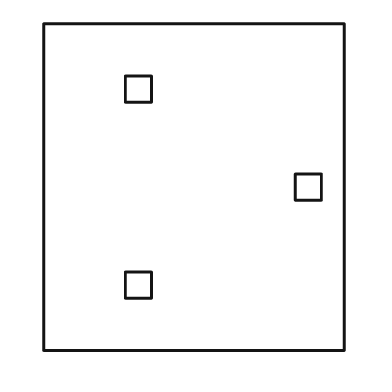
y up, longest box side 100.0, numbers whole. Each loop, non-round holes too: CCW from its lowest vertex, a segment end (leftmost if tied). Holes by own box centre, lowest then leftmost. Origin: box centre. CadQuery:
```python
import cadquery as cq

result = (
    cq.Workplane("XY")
    .moveTo(-46.0, -50.0)
    .lineTo(46.0, -50.0)
    .lineTo(46.0, 50.0)
    .lineTo(-46.0, 50.0)
    .close()
    .moveTo(-21.0, -34.0)
    .lineTo(-13.0, -34.0)
    .lineTo(-13.0, -26.0)
    .lineTo(-21.0, -26.0)
    .close()
    .moveTo(31.0, -4.0)
    .lineTo(39.0, -4.0)
    .lineTo(39.0, 4.0)
    .lineTo(31.0, 4.0)
    .close()
    .moveTo(-21.0, 26.0)
    .lineTo(-13.0, 26.0)
    .lineTo(-13.0, 34.0)
    .lineTo(-21.0, 34.0)
    .close()
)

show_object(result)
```